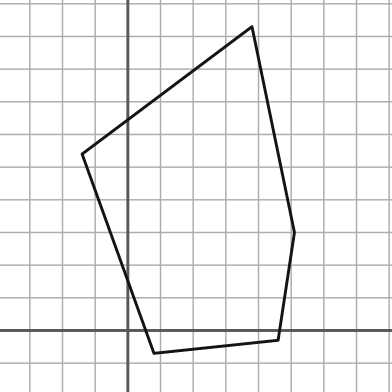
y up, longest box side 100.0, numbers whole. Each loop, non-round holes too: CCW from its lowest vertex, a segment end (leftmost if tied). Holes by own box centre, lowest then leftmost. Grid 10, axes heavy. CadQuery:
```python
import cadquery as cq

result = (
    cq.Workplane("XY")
    .moveTo(8.0, -7.0)
    .lineTo(46.0, -3.0)
    .lineTo(51.0, 30.0)
    .lineTo(38.0, 93.0)
    .lineTo(-14.0, 54.0)
    .close()
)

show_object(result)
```